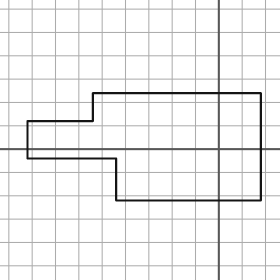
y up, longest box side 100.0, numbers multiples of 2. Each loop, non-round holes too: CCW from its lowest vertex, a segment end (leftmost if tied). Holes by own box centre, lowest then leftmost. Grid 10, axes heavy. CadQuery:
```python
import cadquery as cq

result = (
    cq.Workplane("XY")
    .moveTo(-44.0, -22.0)
    .lineTo(18.0, -22.0)
    .lineTo(18.0, 24.0)
    .lineTo(-54.0, 24.0)
    .lineTo(-54.0, 12.0)
    .lineTo(-82.0, 12.0)
    .lineTo(-82.0, -4.0)
    .lineTo(-44.0, -4.0)
    .close()
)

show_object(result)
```